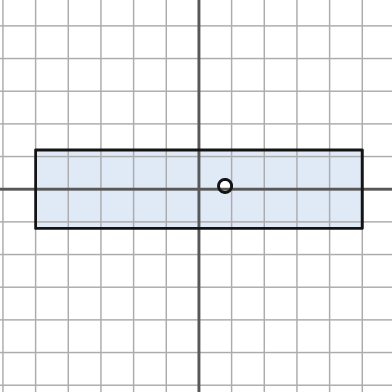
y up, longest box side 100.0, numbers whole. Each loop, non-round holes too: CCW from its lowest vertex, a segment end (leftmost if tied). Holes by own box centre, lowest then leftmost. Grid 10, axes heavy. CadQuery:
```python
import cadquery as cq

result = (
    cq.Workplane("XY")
    .moveTo(-50.0, -12.0)
    .lineTo(50.0, -12.0)
    .lineTo(50.0, 12.0)
    .lineTo(-50.0, 12.0)
    .close()
    .moveTo(8.0, 1.0)
    .circle(2.0)
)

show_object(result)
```